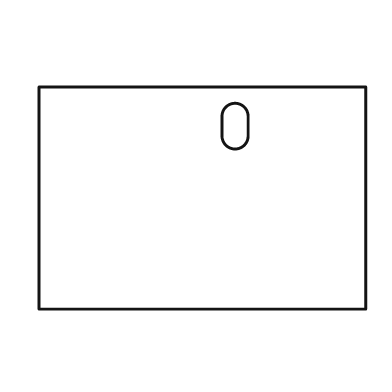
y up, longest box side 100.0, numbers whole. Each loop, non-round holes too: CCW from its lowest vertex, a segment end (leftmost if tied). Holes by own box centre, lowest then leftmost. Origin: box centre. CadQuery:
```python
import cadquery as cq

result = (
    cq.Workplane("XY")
    .moveTo(-50.0, -34.0)
    .lineTo(50.0, -34.0)
    .lineTo(50.0, 34.0)
    .lineTo(-50.0, 34.0)
    .close()
    .moveTo(6.0, 19.0)
    .threePointArc((10.0, 15.0), (14.0, 19.0))
    .lineTo(14.0, 25.0)
    .threePointArc((10.0, 29.0), (6.0, 25.0))
    .close()
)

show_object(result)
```